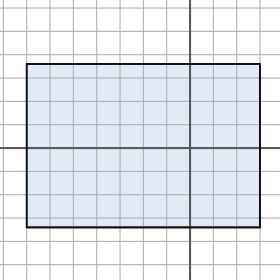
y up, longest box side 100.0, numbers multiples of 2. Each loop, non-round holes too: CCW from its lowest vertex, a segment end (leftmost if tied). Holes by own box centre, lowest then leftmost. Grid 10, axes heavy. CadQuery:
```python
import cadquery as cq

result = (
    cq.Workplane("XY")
    .moveTo(-70.0, -34.0)
    .lineTo(30.0, -34.0)
    .lineTo(30.0, 36.0)
    .lineTo(-70.0, 36.0)
    .close()
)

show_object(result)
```